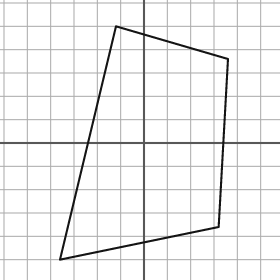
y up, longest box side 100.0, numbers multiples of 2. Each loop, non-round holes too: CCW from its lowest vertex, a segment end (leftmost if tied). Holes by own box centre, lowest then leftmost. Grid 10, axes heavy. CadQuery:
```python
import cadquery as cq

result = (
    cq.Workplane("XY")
    .moveTo(-36.0, -50.0)
    .lineTo(32.0, -36.0)
    .lineTo(36.0, 36.0)
    .lineTo(-12.0, 50.0)
    .close()
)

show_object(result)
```